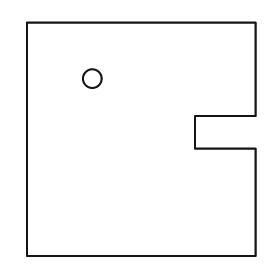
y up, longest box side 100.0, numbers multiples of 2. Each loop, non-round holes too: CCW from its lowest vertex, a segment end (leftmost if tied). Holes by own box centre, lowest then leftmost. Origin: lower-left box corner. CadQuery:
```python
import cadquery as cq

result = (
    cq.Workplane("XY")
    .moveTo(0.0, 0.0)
    .lineTo(98.0, 0.0)
    .lineTo(98.0, 46.0)
    .lineTo(72.0, 46.0)
    .lineTo(72.0, 60.0)
    .lineTo(98.0, 60.0)
    .lineTo(98.0, 100.0)
    .lineTo(0.0, 100.0)
    .close()
    .moveTo(28.0, 76.0)
    .circle(4.0)
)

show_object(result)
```